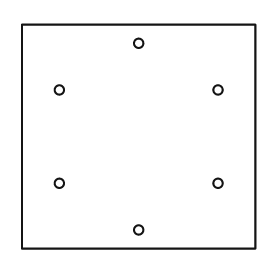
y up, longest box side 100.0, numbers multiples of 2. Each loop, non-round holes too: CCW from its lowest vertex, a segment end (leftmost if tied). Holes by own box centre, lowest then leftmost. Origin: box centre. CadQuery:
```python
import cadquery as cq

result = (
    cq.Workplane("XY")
    .moveTo(-50.0, -48.0)
    .lineTo(50.0, -48.0)
    .lineTo(50.0, 48.0)
    .lineTo(-50.0, 48.0)
    .close()
    .moveTo(0.0, -40.0)
    .circle(2.0)
    .moveTo(-34.0, -20.0)
    .circle(2.0)
    .moveTo(34.0, -20.0)
    .circle(2.0)
    .moveTo(-34.0, 20.0)
    .circle(2.0)
    .moveTo(34.0, 20.0)
    .circle(2.0)
    .moveTo(0.0, 40.0)
    .circle(2.0)
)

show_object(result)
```